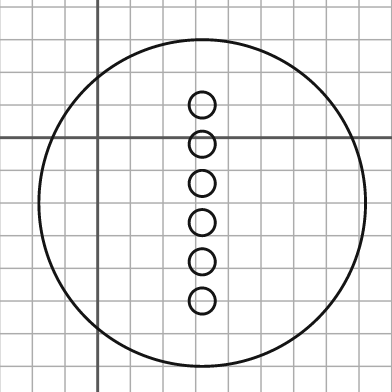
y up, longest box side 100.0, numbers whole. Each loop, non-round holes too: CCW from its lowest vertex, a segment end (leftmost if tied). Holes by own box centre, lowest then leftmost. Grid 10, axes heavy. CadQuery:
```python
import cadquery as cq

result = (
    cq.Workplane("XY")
    .moveTo(32.0, -20.0)
    .circle(50.0)
    .moveTo(32.0, -50.0)
    .circle(4.0)
    .moveTo(32.0, -38.0)
    .circle(4.0)
    .moveTo(32.0, -26.0)
    .circle(4.0)
    .moveTo(32.0, -14.0)
    .circle(4.0)
    .moveTo(32.0, -2.0)
    .circle(4.0)
    .moveTo(32.0, 10.0)
    .circle(4.0)
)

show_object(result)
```